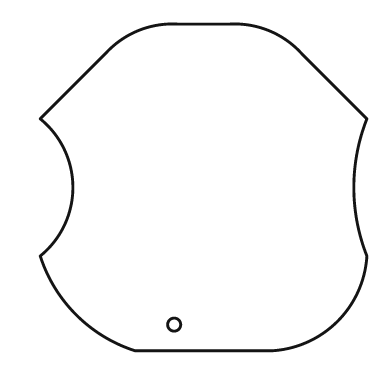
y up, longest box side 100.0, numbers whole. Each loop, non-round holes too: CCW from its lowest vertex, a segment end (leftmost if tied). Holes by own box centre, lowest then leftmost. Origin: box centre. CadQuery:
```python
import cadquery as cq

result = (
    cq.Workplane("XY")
    .moveTo(-21.0, -50.0)
    .lineTo(21.0, -50.0)
    .threePointArc((41.0, -41.0), (50.0, -21.0))
    .threePointArc((46.0, 0.0), (50.0, 21.0))
    .lineTo(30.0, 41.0)
    .threePointArc((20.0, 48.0), (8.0, 50.0))
    .lineTo(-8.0, 50.0)
    .threePointArc((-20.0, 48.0), (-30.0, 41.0))
    .lineTo(-50.0, 21.0)
    .threePointArc((-40.0, 0.0), (-50.0, -21.0))
    .threePointArc((-39.0, -39.0), (-21.0, -50.0))
    .close()
    .moveTo(-9.0, -42.0)
    .circle(2.0)
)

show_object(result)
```